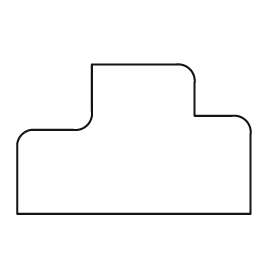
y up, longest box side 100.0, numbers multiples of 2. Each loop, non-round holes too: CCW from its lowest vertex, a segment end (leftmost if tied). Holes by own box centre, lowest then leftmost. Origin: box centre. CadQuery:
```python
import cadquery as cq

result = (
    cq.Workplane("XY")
    .moveTo(-50.0, -32.0)
    .lineTo(50.0, -32.0)
    .lineTo(50.0, 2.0)
    .threePointArc((48.0, 8.0), (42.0, 10.0))
    .lineTo(26.0, 10.0)
    .lineTo(26.0, 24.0)
    .threePointArc((24.0, 30.0), (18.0, 32.0))
    .lineTo(-18.0, 32.0)
    .lineTo(-18.0, 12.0)
    .threePointArc((-20.0, 6.0), (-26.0, 4.0))
    .lineTo(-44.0, 4.0)
    .threePointArc((-48.0, 2.0), (-50.0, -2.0))
    .close()
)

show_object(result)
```